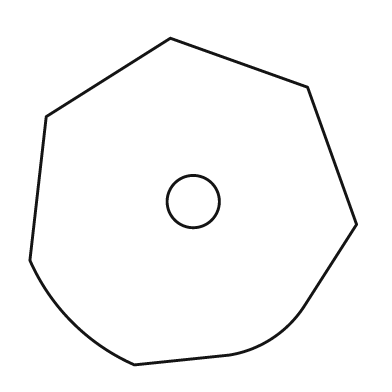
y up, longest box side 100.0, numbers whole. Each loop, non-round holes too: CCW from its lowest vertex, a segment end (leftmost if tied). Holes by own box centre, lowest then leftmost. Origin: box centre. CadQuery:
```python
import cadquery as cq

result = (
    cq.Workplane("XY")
    .moveTo(-18.0, -50.0)
    .lineTo(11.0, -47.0)
    .threePointArc((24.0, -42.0), (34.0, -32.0))
    .lineTo(50.0, -7.0)
    .lineTo(35.0, 35.0)
    .lineTo(-7.0, 50.0)
    .lineTo(-45.0, 26.0)
    .lineTo(-50.0, -18.0)
    .threePointArc((-37.0, -37.0), (-18.0, -50.0))
    .close()
    .moveTo(0.0, 0.0)
    .circle(8.0)
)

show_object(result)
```